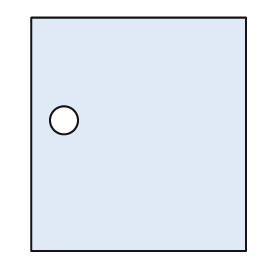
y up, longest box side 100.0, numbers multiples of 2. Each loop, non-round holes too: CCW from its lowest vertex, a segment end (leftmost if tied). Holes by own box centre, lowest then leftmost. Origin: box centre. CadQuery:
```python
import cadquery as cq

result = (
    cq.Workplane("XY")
    .moveTo(-46.0, -50.0)
    .lineTo(46.0, -50.0)
    .lineTo(46.0, 50.0)
    .lineTo(-46.0, 50.0)
    .close()
    .moveTo(-32.0, 6.0)
    .circle(6.0)
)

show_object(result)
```